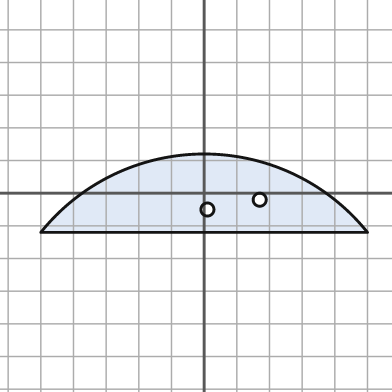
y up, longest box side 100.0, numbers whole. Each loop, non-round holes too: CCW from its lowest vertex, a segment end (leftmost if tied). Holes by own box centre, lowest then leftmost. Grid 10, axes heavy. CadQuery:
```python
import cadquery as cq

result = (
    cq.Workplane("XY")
    .moveTo(-50.0, -12.0)
    .lineTo(50.0, -12.0)
    .threePointArc((0.0, 12.0), (-50.0, -12.0))
    .close()
    .moveTo(1.0, -5.0)
    .circle(2.0)
    .moveTo(17.0, -2.0)
    .circle(2.0)
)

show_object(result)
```